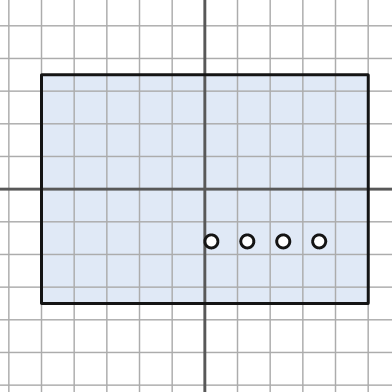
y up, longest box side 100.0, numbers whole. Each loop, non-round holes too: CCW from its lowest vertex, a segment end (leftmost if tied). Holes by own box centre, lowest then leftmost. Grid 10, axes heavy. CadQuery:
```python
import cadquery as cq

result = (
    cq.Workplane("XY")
    .moveTo(-50.0, -35.0)
    .lineTo(50.0, -35.0)
    .lineTo(50.0, 35.0)
    .lineTo(-50.0, 35.0)
    .close()
    .moveTo(2.0, -16.0)
    .circle(2.0)
    .moveTo(13.0, -16.0)
    .circle(2.0)
    .moveTo(24.0, -16.0)
    .circle(2.0)
    .moveTo(35.0, -16.0)
    .circle(2.0)
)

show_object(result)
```